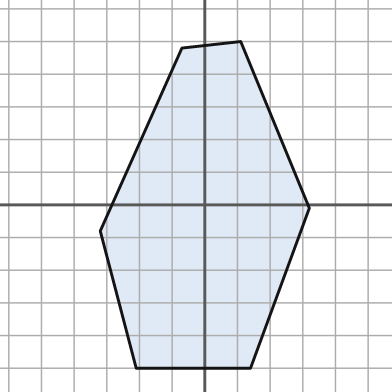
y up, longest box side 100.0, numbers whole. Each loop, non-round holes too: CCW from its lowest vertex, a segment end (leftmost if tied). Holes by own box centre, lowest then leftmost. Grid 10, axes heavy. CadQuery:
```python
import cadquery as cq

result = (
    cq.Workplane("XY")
    .moveTo(-21.0, -50.0)
    .lineTo(14.0, -50.0)
    .lineTo(32.0, -1.0)
    .lineTo(11.0, 50.0)
    .lineTo(-7.0, 48.0)
    .lineTo(-32.0, -8.0)
    .close()
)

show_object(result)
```